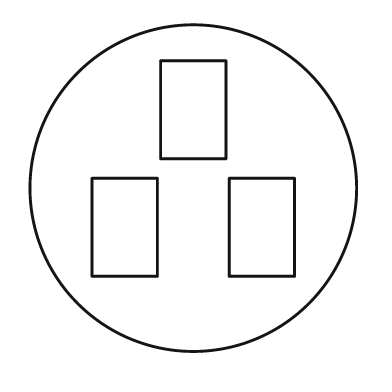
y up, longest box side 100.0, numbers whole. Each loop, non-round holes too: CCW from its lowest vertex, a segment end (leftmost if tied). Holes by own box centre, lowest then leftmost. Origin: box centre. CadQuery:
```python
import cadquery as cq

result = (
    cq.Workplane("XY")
    .moveTo(0.0, 0.0)
    .circle(50.0)
    .moveTo(-31.0, -27.0)
    .lineTo(-11.0, -27.0)
    .lineTo(-11.0, 3.0)
    .lineTo(-31.0, 3.0)
    .close()
    .moveTo(11.0, -27.0)
    .lineTo(31.0, -27.0)
    .lineTo(31.0, 3.0)
    .lineTo(11.0, 3.0)
    .close()
    .moveTo(-10.0, 9.0)
    .lineTo(10.0, 9.0)
    .lineTo(10.0, 39.0)
    .lineTo(-10.0, 39.0)
    .close()
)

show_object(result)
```